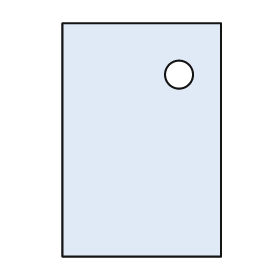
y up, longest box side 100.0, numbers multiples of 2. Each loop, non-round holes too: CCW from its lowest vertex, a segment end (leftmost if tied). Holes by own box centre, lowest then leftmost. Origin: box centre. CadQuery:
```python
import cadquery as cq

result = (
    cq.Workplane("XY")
    .moveTo(-34.0, -50.0)
    .lineTo(34.0, -50.0)
    .lineTo(34.0, 50.0)
    .lineTo(-34.0, 50.0)
    .close()
    .moveTo(16.0, 28.0)
    .circle(6.0)
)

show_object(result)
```